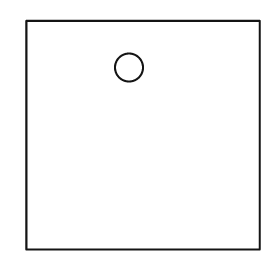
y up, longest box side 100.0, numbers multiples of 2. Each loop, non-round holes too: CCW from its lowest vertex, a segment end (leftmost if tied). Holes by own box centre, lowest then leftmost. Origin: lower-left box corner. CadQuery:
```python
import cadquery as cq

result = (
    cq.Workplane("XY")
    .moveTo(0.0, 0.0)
    .lineTo(100.0, 0.0)
    .lineTo(100.0, 98.0)
    .lineTo(0.0, 98.0)
    .close()
    .moveTo(44.0, 78.0)
    .circle(6.0)
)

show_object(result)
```